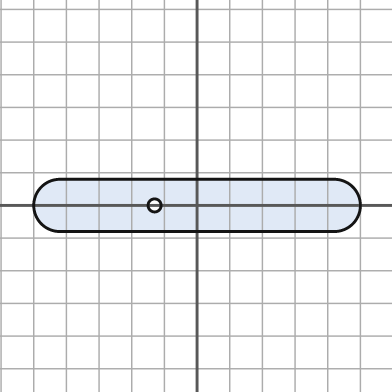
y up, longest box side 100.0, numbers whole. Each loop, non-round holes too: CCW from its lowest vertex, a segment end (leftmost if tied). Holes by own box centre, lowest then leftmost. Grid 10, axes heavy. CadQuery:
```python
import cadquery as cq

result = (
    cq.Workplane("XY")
    .moveTo(-42.0, -8.0)
    .lineTo(42.0, -8.0)
    .threePointArc((50.0, 0.0), (42.0, 8.0))
    .lineTo(-42.0, 8.0)
    .threePointArc((-50.0, 0.0), (-42.0, -8.0))
    .close()
    .moveTo(-13.0, 0.0)
    .circle(2.0)
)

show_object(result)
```